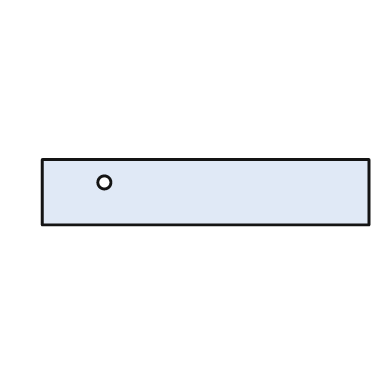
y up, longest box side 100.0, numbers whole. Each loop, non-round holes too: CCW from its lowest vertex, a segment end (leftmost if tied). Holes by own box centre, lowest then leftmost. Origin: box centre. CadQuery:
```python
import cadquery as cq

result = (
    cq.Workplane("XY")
    .moveTo(-50.0, -10.0)
    .lineTo(50.0, -10.0)
    .lineTo(50.0, 10.0)
    .lineTo(-50.0, 10.0)
    .close()
    .moveTo(-31.0, 3.0)
    .circle(2.0)
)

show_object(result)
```